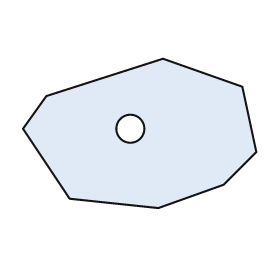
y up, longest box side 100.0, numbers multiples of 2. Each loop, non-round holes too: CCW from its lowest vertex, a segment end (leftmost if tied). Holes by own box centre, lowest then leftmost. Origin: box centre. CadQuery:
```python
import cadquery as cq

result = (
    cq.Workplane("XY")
    .moveTo(8.0, -32.0)
    .lineTo(36.0, -22.0)
    .lineTo(50.0, -8.0)
    .lineTo(44.0, 20.0)
    .lineTo(10.0, 32.0)
    .lineTo(-40.0, 16.0)
    .lineTo(-50.0, 2.0)
    .lineTo(-30.0, -28.0)
    .close()
    .moveTo(-4.0, 2.0)
    .circle(6.0)
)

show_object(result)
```